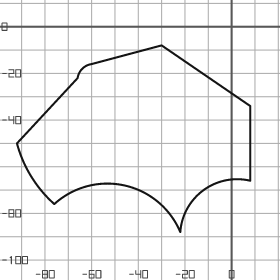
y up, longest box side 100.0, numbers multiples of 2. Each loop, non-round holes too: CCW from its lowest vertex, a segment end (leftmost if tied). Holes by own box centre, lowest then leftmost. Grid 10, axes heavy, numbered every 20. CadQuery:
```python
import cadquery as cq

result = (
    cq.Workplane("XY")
    .moveTo(-22.0, -88.0)
    .threePointArc((-12.0, -70.0), (8.0, -66.0))
    .lineTo(8.0, -34.0)
    .lineTo(-30.0, -8.0)
    .lineTo(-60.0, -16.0)
    .threePointArc((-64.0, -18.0), (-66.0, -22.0))
    .lineTo(-92.0, -50.0)
    .threePointArc((-86.0, -64.0), (-76.0, -76.0))
    .threePointArc((-46.0, -68.0), (-22.0, -88.0))
    .close()
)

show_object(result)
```